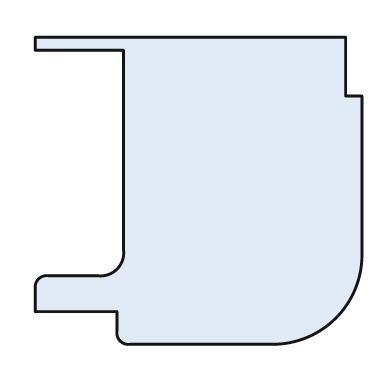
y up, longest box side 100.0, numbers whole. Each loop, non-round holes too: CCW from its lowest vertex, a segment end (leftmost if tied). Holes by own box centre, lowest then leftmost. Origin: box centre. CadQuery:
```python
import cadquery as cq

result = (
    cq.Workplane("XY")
    .moveTo(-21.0, -47.0)
    .lineTo(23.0, -47.0)
    .threePointArc((42.0, -39.0), (50.0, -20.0))
    .lineTo(50.0, 29.0)
    .lineTo(45.0, 29.0)
    .lineTo(45.0, 47.0)
    .lineTo(-50.0, 47.0)
    .lineTo(-50.0, 43.0)
    .lineTo(-23.0, 43.0)
    .lineTo(-23.0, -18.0)
    .threePointArc((-25.0, -24.0), (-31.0, -26.0))
    .lineTo(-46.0, -26.0)
    .threePointArc((-49.0, -27.0), (-50.0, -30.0))
    .lineTo(-50.0, -37.0)
    .lineTo(-25.0, -37.0)
    .lineTo(-25.0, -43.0)
    .threePointArc((-24.0, -46.0), (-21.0, -47.0))
    .close()
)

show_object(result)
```